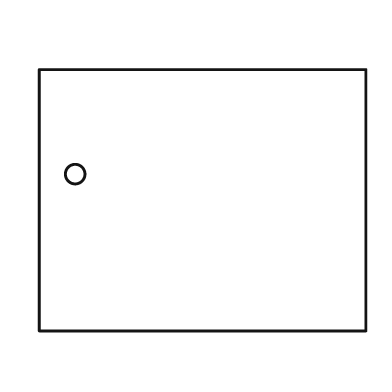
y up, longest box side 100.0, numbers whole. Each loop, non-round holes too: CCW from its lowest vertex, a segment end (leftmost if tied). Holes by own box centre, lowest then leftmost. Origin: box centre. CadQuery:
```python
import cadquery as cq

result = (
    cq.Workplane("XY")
    .moveTo(-50.0, -40.0)
    .lineTo(50.0, -40.0)
    .lineTo(50.0, 40.0)
    .lineTo(-50.0, 40.0)
    .close()
    .moveTo(-39.0, 8.0)
    .circle(3.0)
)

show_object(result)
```